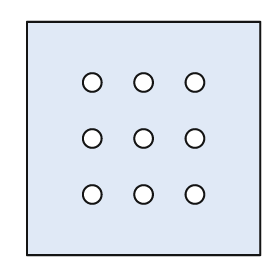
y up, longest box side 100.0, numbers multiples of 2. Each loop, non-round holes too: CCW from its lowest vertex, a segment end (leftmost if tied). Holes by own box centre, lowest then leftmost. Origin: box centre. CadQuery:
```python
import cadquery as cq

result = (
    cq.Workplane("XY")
    .moveTo(-50.0, -50.0)
    .lineTo(50.0, -50.0)
    .lineTo(50.0, 50.0)
    .lineTo(-50.0, 50.0)
    .close()
    .moveTo(-22.0, -24.0)
    .circle(4.0)
    .moveTo(0.0, -24.0)
    .circle(4.0)
    .moveTo(22.0, -24.0)
    .circle(4.0)
    .moveTo(-22.0, 0.0)
    .circle(4.0)
    .moveTo(0.0, 0.0)
    .circle(4.0)
    .moveTo(22.0, 0.0)
    .circle(4.0)
    .moveTo(-22.0, 24.0)
    .circle(4.0)
    .moveTo(0.0, 24.0)
    .circle(4.0)
    .moveTo(22.0, 24.0)
    .circle(4.0)
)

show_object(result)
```